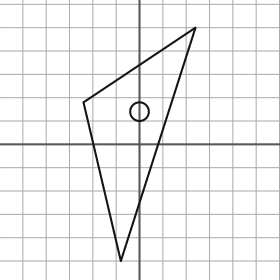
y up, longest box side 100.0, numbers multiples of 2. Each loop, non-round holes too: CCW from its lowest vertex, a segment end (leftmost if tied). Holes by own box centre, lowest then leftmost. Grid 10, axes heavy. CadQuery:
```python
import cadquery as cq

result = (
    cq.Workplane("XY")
    .moveTo(-8.0, -50.0)
    .lineTo(24.0, 50.0)
    .lineTo(-24.0, 18.0)
    .close()
    .moveTo(0.0, 14.0)
    .circle(4.0)
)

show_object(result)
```